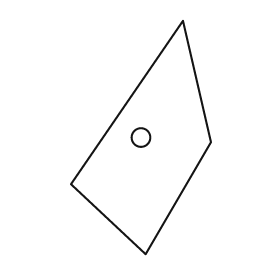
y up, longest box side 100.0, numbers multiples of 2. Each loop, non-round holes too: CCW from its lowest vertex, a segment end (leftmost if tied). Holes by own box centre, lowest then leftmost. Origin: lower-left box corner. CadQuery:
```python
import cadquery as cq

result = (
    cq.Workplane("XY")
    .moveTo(32.0, 0.0)
    .lineTo(60.0, 48.0)
    .lineTo(48.0, 100.0)
    .lineTo(0.0, 30.0)
    .close()
    .moveTo(30.0, 50.0)
    .circle(4.0)
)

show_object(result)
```